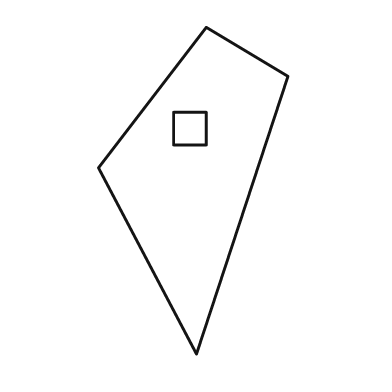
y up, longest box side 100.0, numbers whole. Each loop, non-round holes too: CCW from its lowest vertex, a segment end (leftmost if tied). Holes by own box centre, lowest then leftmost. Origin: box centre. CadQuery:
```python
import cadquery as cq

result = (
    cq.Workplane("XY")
    .moveTo(1.0, -50.0)
    .lineTo(29.0, 35.0)
    .lineTo(4.0, 50.0)
    .lineTo(-29.0, 7.0)
    .close()
    .moveTo(-6.0, 14.0)
    .lineTo(4.0, 14.0)
    .lineTo(4.0, 24.0)
    .lineTo(-6.0, 24.0)
    .close()
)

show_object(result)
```